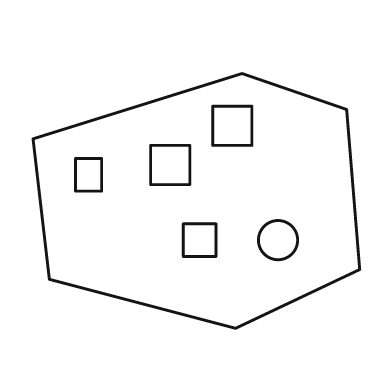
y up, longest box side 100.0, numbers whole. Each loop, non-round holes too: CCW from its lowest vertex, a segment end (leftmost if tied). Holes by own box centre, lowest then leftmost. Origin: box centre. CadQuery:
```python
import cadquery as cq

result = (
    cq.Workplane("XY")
    .moveTo(12.0, -39.0)
    .lineTo(50.0, -21.0)
    .lineTo(46.0, 28.0)
    .lineTo(14.0, 39.0)
    .lineTo(-50.0, 19.0)
    .lineTo(-45.0, -24.0)
    .close()
    .moveTo(-4.0, -17.0)
    .lineTo(6.0, -17.0)
    .lineTo(6.0, -7.0)
    .lineTo(-4.0, -7.0)
    .close()
    .moveTo(25.0, -12.0)
    .circle(6.0)
    .moveTo(-37.0, 3.0)
    .lineTo(-29.0, 3.0)
    .lineTo(-29.0, 13.0)
    .lineTo(-37.0, 13.0)
    .close()
    .moveTo(-14.0, 5.0)
    .lineTo(-2.0, 5.0)
    .lineTo(-2.0, 17.0)
    .lineTo(-14.0, 17.0)
    .close()
    .moveTo(5.0, 17.0)
    .lineTo(17.0, 17.0)
    .lineTo(17.0, 29.0)
    .lineTo(5.0, 29.0)
    .close()
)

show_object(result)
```